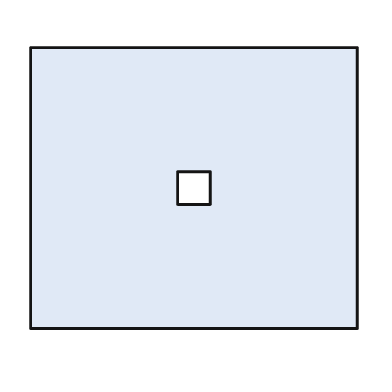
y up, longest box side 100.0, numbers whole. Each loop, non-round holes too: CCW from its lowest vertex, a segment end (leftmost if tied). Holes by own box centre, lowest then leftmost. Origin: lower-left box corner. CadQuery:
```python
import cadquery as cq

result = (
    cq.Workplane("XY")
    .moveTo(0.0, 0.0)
    .lineTo(100.0, 0.0)
    .lineTo(100.0, 86.0)
    .lineTo(0.0, 86.0)
    .close()
    .moveTo(45.0, 38.0)
    .lineTo(55.0, 38.0)
    .lineTo(55.0, 48.0)
    .lineTo(45.0, 48.0)
    .close()
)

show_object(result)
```